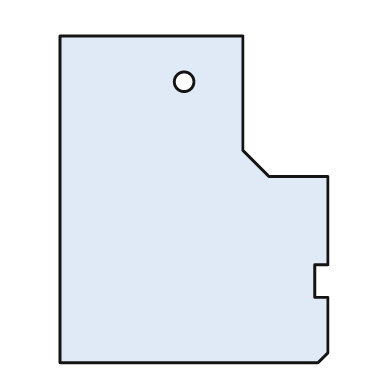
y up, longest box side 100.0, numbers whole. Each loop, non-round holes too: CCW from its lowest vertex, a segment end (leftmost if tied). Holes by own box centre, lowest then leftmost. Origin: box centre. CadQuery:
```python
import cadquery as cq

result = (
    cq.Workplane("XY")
    .moveTo(-41.0, -50.0)
    .lineTo(38.0, -50.0)
    .lineTo(41.0, -47.0)
    .lineTo(41.0, -30.0)
    .lineTo(37.0, -30.0)
    .lineTo(37.0, -20.0)
    .lineTo(41.0, -20.0)
    .lineTo(41.0, 7.0)
    .lineTo(23.0, 7.0)
    .lineTo(15.0, 15.0)
    .lineTo(15.0, 50.0)
    .lineTo(-41.0, 50.0)
    .close()
    .moveTo(-3.0, 36.0)
    .circle(3.0)
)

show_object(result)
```